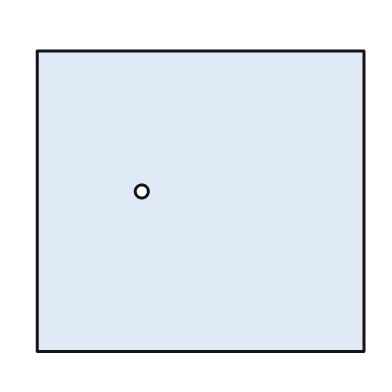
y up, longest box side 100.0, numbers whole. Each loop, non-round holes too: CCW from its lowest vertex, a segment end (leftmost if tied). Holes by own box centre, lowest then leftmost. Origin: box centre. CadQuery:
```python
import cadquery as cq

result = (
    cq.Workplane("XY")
    .moveTo(-50.0, -46.0)
    .lineTo(50.0, -46.0)
    .lineTo(50.0, 46.0)
    .lineTo(-50.0, 46.0)
    .close()
    .moveTo(-18.0, 3.0)
    .circle(2.0)
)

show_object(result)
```